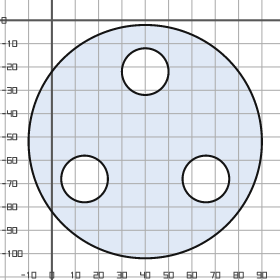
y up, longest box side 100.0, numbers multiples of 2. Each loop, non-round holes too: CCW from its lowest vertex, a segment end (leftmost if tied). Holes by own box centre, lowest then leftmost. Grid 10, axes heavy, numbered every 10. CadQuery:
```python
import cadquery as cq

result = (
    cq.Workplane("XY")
    .moveTo(40.0, -52.0)
    .circle(50.0)
    .moveTo(14.0, -68.0)
    .circle(10.0)
    .moveTo(66.0, -68.0)
    .circle(10.0)
    .moveTo(40.0, -22.0)
    .circle(10.0)
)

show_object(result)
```